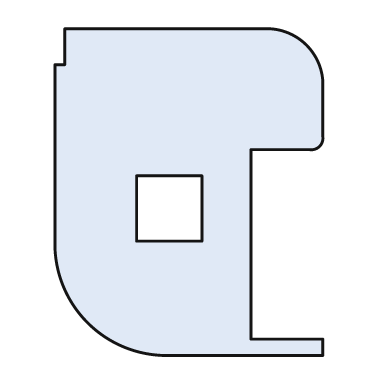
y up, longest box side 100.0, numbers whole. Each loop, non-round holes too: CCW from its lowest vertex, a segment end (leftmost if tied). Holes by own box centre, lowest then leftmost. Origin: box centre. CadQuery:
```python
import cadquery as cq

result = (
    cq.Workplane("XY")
    .moveTo(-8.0, -50.0)
    .lineTo(41.0, -50.0)
    .lineTo(41.0, -45.0)
    .lineTo(19.0, -45.0)
    .lineTo(19.0, 13.0)
    .lineTo(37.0, 13.0)
    .threePointArc((40.0, 14.0), (41.0, 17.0))
    .lineTo(41.0, 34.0)
    .threePointArc((36.0, 45.0), (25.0, 50.0))
    .lineTo(-38.0, 50.0)
    .lineTo(-38.0, 39.0)
    .lineTo(-41.0, 39.0)
    .lineTo(-41.0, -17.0)
    .threePointArc((-31.0, -40.0), (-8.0, -50.0))
    .close()
    .moveTo(-16.0, -15.0)
    .lineTo(4.0, -15.0)
    .lineTo(4.0, 5.0)
    .lineTo(-16.0, 5.0)
    .close()
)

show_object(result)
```